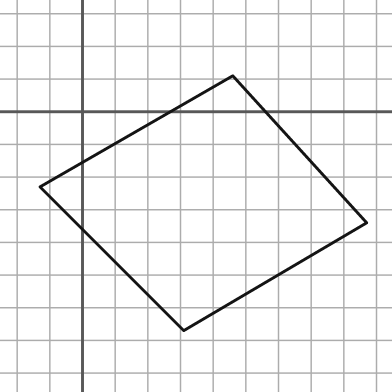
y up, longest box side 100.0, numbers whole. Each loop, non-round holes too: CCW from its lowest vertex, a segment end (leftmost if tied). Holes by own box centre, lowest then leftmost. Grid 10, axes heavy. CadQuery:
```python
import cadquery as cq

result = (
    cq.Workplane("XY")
    .moveTo(31.0, -67.0)
    .lineTo(87.0, -34.0)
    .lineTo(46.0, 11.0)
    .lineTo(-13.0, -23.0)
    .close()
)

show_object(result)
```